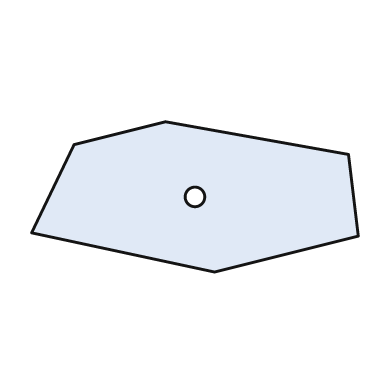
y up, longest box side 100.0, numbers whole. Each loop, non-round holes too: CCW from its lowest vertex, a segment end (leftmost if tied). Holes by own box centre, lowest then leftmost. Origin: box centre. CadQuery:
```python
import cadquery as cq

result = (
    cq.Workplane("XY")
    .moveTo(6.0, -23.0)
    .lineTo(50.0, -12.0)
    .lineTo(47.0, 13.0)
    .lineTo(-9.0, 23.0)
    .lineTo(-37.0, 16.0)
    .lineTo(-50.0, -11.0)
    .close()
    .moveTo(0.0, 0.0)
    .circle(3.0)
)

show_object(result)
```